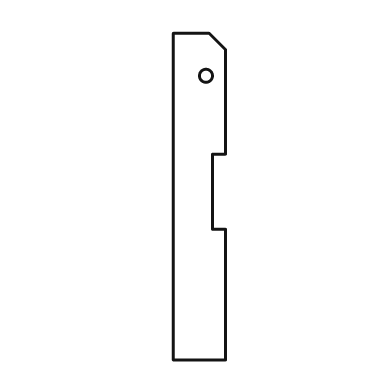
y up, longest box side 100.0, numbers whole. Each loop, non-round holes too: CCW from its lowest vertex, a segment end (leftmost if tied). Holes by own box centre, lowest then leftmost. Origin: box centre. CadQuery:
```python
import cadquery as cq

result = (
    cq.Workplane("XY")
    .moveTo(-8.0, -50.0)
    .lineTo(8.0, -50.0)
    .lineTo(8.0, -10.0)
    .lineTo(4.0, -10.0)
    .lineTo(4.0, 13.0)
    .lineTo(8.0, 13.0)
    .lineTo(8.0, 45.0)
    .lineTo(3.0, 50.0)
    .lineTo(-8.0, 50.0)
    .close()
    .moveTo(2.0, 37.0)
    .circle(2.0)
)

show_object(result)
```